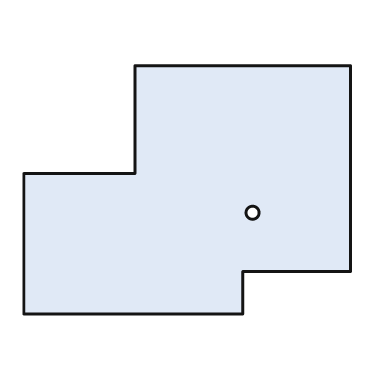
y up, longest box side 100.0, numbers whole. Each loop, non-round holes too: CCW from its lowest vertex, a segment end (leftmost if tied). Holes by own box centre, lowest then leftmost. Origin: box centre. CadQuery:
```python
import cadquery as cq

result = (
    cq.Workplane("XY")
    .moveTo(-50.0, -38.0)
    .lineTo(17.0, -38.0)
    .lineTo(17.0, -25.0)
    .lineTo(50.0, -25.0)
    .lineTo(50.0, 38.0)
    .lineTo(-16.0, 38.0)
    .lineTo(-16.0, 5.0)
    .lineTo(-50.0, 5.0)
    .close()
    .moveTo(20.0, -7.0)
    .circle(2.0)
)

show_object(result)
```